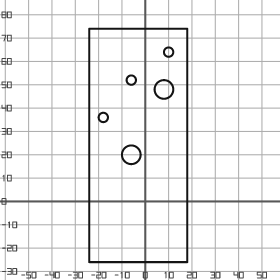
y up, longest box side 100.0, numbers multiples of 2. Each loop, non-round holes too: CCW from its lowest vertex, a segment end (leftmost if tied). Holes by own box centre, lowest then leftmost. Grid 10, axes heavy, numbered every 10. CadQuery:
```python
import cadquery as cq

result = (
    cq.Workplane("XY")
    .moveTo(-24.0, -26.0)
    .lineTo(18.0, -26.0)
    .lineTo(18.0, 74.0)
    .lineTo(-24.0, 74.0)
    .close()
    .moveTo(-6.0, 20.0)
    .circle(4.0)
    .moveTo(-18.0, 36.0)
    .circle(2.0)
    .moveTo(8.0, 48.0)
    .circle(4.0)
    .moveTo(-6.0, 52.0)
    .circle(2.0)
    .moveTo(10.0, 64.0)
    .circle(2.0)
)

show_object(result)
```